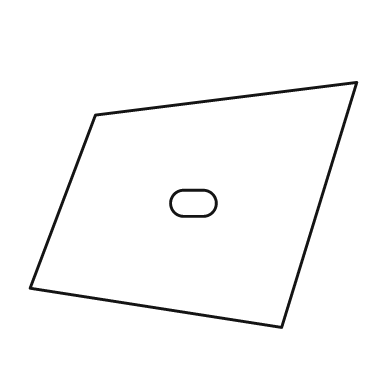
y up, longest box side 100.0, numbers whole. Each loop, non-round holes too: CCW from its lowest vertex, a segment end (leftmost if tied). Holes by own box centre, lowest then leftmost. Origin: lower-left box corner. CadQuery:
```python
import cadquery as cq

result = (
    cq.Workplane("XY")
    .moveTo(77.0, 0.0)
    .lineTo(100.0, 75.0)
    .lineTo(20.0, 65.0)
    .lineTo(0.0, 12.0)
    .close()
    .moveTo(47.0, 34.0)
    .lineTo(53.0, 34.0)
    .threePointArc((57.0, 38.0), (53.0, 42.0))
    .lineTo(47.0, 42.0)
    .threePointArc((43.0, 38.0), (47.0, 34.0))
    .close()
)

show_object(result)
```